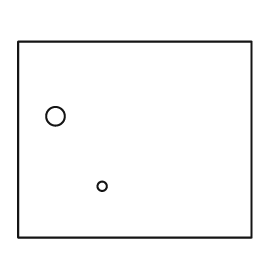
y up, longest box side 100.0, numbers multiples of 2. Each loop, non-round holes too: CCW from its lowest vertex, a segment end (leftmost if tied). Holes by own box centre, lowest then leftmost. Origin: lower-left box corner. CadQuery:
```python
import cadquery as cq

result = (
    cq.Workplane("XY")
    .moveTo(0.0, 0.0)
    .lineTo(100.0, 0.0)
    .lineTo(100.0, 84.0)
    .lineTo(0.0, 84.0)
    .close()
    .moveTo(36.0, 22.0)
    .circle(2.0)
    .moveTo(16.0, 52.0)
    .circle(4.0)
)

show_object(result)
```